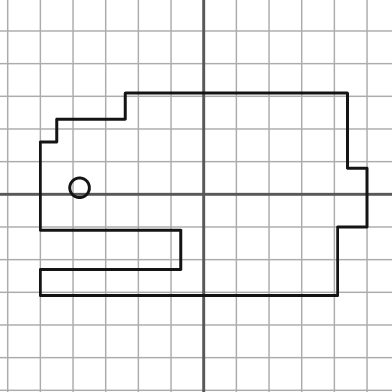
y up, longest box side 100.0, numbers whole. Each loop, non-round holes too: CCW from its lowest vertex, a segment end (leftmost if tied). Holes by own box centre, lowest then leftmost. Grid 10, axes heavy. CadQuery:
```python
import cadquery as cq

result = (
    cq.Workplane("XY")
    .moveTo(-50.0, -31.0)
    .lineTo(41.0, -31.0)
    .lineTo(41.0, -10.0)
    .lineTo(50.0, -10.0)
    .lineTo(50.0, 8.0)
    .lineTo(44.0, 8.0)
    .lineTo(44.0, 31.0)
    .lineTo(-24.0, 31.0)
    .lineTo(-24.0, 23.0)
    .lineTo(-45.0, 23.0)
    .lineTo(-45.0, 16.0)
    .lineTo(-50.0, 16.0)
    .lineTo(-50.0, -11.0)
    .lineTo(-7.0, -11.0)
    .lineTo(-7.0, -23.0)
    .lineTo(-50.0, -23.0)
    .close()
    .moveTo(-38.0, 2.0)
    .circle(3.0)
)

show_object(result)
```